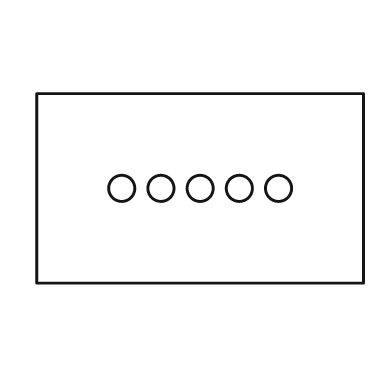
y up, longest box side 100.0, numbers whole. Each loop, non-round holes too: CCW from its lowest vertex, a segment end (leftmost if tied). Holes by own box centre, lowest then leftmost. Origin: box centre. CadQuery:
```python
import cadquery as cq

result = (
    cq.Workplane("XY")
    .moveTo(-50.0, -29.0)
    .lineTo(50.0, -29.0)
    .lineTo(50.0, 29.0)
    .lineTo(-50.0, 29.0)
    .close()
    .moveTo(-24.0, 0.0)
    .circle(4.0)
    .moveTo(-12.0, 0.0)
    .circle(4.0)
    .moveTo(0.0, 0.0)
    .circle(4.0)
    .moveTo(12.0, 0.0)
    .circle(4.0)
    .moveTo(24.0, 0.0)
    .circle(4.0)
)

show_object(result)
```